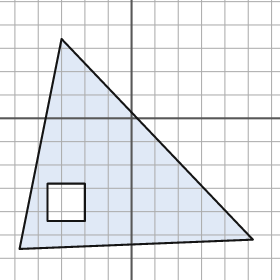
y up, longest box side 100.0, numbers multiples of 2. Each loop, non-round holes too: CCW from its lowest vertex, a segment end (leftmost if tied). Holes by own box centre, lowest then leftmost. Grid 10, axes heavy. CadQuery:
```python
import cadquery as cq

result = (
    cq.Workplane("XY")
    .moveTo(-48.0, -56.0)
    .lineTo(52.0, -52.0)
    .lineTo(-30.0, 34.0)
    .close()
    .moveTo(-36.0, -44.0)
    .lineTo(-20.0, -44.0)
    .lineTo(-20.0, -28.0)
    .lineTo(-36.0, -28.0)
    .close()
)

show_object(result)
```